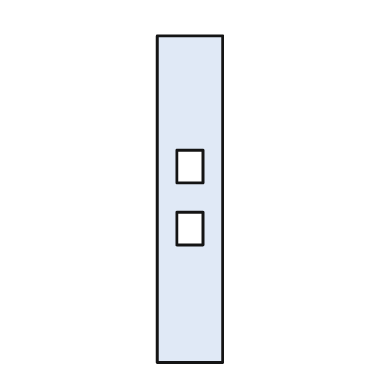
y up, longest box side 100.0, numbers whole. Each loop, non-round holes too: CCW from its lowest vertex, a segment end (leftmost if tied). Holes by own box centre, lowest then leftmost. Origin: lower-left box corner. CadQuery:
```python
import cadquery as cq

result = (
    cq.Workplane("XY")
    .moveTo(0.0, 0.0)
    .lineTo(20.0, 0.0)
    .lineTo(20.0, 100.0)
    .lineTo(0.0, 100.0)
    .close()
    .moveTo(6.0, 36.0)
    .lineTo(14.0, 36.0)
    .lineTo(14.0, 46.0)
    .lineTo(6.0, 46.0)
    .close()
    .moveTo(6.0, 55.0)
    .lineTo(14.0, 55.0)
    .lineTo(14.0, 65.0)
    .lineTo(6.0, 65.0)
    .close()
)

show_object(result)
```